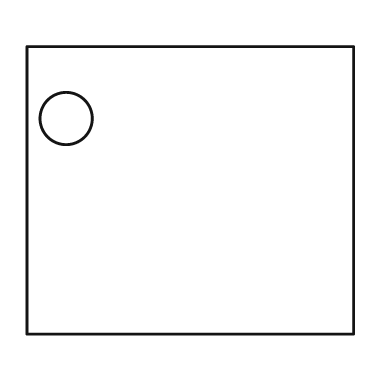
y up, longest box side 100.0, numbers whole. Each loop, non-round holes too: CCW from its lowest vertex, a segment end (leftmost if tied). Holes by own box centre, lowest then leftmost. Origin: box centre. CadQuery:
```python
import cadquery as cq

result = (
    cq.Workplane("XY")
    .moveTo(-50.0, -44.0)
    .lineTo(50.0, -44.0)
    .lineTo(50.0, 44.0)
    .lineTo(-50.0, 44.0)
    .close()
    .moveTo(-38.0, 22.0)
    .circle(8.0)
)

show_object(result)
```